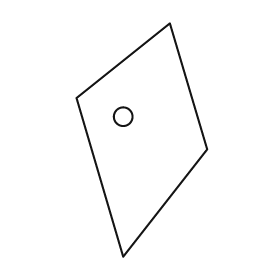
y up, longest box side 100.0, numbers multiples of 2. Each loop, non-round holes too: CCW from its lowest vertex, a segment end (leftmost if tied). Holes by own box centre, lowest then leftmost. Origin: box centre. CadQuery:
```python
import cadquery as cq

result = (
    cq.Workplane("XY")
    .moveTo(-8.0, -50.0)
    .lineTo(28.0, -4.0)
    .lineTo(12.0, 50.0)
    .lineTo(-28.0, 18.0)
    .close()
    .moveTo(-8.0, 10.0)
    .circle(4.0)
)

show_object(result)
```